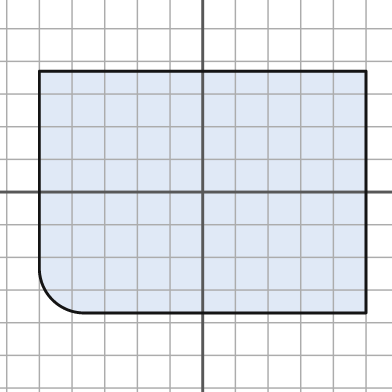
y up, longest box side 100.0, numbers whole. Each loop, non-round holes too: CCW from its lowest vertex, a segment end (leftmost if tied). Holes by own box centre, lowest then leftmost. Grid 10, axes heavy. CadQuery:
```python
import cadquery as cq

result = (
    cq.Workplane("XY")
    .moveTo(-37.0, -37.0)
    .lineTo(50.0, -37.0)
    .lineTo(50.0, 37.0)
    .lineTo(-50.0, 37.0)
    .lineTo(-50.0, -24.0)
    .threePointArc((-46.0, -33.0), (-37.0, -37.0))
    .close()
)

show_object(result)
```